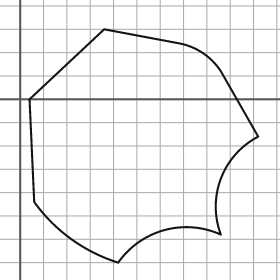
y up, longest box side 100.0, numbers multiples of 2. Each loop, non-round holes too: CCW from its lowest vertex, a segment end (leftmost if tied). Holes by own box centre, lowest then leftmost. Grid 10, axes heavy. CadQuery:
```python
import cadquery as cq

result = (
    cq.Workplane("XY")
    .moveTo(42.0, -70.0)
    .threePointArc((62.0, -56.0), (86.0, -58.0))
    .threePointArc((86.0, -34.0), (102.0, -16.0))
    .lineTo(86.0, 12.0)
    .threePointArc((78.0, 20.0), (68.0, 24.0))
    .lineTo(36.0, 30.0)
    .lineTo(4.0, 0.0)
    .lineTo(6.0, -44.0)
    .threePointArc((22.0, -60.0), (42.0, -70.0))
    .close()
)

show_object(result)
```